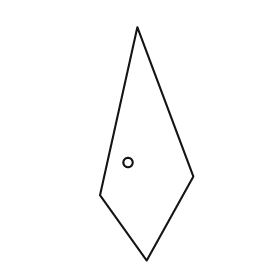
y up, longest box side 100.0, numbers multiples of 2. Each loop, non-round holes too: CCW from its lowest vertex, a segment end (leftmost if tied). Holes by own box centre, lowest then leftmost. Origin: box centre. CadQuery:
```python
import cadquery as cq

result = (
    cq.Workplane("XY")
    .moveTo(0.0, -50.0)
    .lineTo(20.0, -14.0)
    .lineTo(-4.0, 50.0)
    .lineTo(-20.0, -22.0)
    .close()
    .moveTo(-8.0, -8.0)
    .circle(2.0)
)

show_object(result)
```